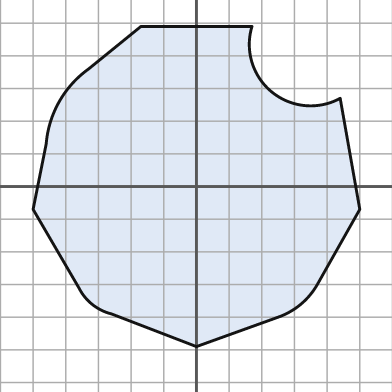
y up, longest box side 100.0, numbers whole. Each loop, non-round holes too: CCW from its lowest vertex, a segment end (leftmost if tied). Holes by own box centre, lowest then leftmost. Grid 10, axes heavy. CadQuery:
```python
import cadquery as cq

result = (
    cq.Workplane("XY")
    .moveTo(0.0, -49.0)
    .lineTo(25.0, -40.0)
    .threePointArc((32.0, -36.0), (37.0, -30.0))
    .lineTo(50.0, -7.0)
    .lineTo(44.0, 27.0)
    .threePointArc((23.0, 29.0), (17.0, 49.0))
    .lineTo(-17.0, 49.0)
    .lineTo(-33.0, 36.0)
    .threePointArc((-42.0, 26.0), (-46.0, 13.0))
    .lineTo(-50.0, -7.0)
    .lineTo(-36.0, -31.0)
    .threePointArc((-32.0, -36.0), (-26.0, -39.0))
    .close()
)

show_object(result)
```